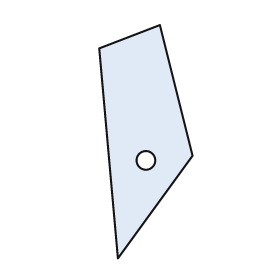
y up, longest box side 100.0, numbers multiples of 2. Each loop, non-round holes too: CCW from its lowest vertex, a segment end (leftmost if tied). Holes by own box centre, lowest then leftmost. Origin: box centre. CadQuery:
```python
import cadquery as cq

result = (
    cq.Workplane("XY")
    .moveTo(-12.0, -50.0)
    .lineTo(20.0, -6.0)
    .lineTo(6.0, 50.0)
    .lineTo(-20.0, 40.0)
    .close()
    .moveTo(0.0, -8.0)
    .circle(4.0)
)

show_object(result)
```